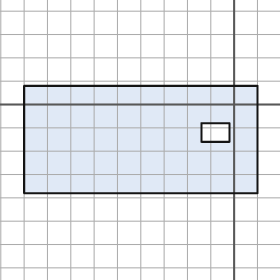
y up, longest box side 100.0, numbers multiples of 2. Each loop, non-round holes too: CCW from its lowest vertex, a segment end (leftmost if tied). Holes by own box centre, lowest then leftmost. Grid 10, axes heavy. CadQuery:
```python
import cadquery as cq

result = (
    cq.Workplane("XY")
    .moveTo(-90.0, -38.0)
    .lineTo(10.0, -38.0)
    .lineTo(10.0, 8.0)
    .lineTo(-90.0, 8.0)
    .close()
    .moveTo(-14.0, -16.0)
    .lineTo(-2.0, -16.0)
    .lineTo(-2.0, -8.0)
    .lineTo(-14.0, -8.0)
    .close()
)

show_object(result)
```